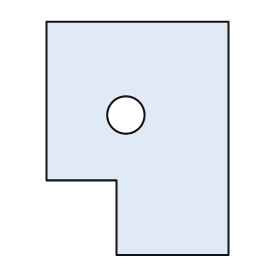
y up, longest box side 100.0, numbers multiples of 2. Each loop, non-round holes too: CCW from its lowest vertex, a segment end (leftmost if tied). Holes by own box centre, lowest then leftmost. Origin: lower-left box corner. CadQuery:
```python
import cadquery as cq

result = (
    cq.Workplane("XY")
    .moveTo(30.0, 0.0)
    .lineTo(78.0, 0.0)
    .lineTo(78.0, 100.0)
    .lineTo(0.0, 100.0)
    .lineTo(0.0, 32.0)
    .lineTo(30.0, 32.0)
    .close()
    .moveTo(34.0, 60.0)
    .circle(8.0)
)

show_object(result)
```